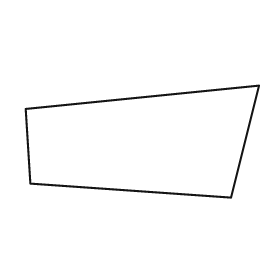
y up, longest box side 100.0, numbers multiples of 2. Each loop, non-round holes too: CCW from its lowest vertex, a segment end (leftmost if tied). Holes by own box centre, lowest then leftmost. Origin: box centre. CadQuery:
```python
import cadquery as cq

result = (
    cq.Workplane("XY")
    .moveTo(38.0, -24.0)
    .lineTo(50.0, 24.0)
    .lineTo(-50.0, 14.0)
    .lineTo(-48.0, -18.0)
    .close()
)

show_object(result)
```